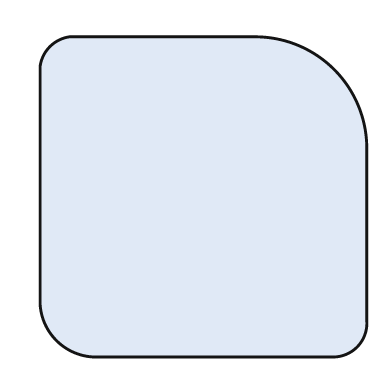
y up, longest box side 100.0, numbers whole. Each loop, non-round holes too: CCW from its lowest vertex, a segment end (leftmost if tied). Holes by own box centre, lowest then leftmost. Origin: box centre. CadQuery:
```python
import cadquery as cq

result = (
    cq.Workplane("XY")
    .moveTo(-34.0, -49.0)
    .lineTo(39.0, -49.0)
    .threePointArc((47.0, -46.0), (50.0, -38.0))
    .lineTo(50.0, 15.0)
    .threePointArc((40.0, 39.0), (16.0, 49.0))
    .lineTo(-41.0, 49.0)
    .threePointArc((-47.0, 46.0), (-50.0, 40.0))
    .lineTo(-50.0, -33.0)
    .threePointArc((-45.0, -44.0), (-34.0, -49.0))
    .close()
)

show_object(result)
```